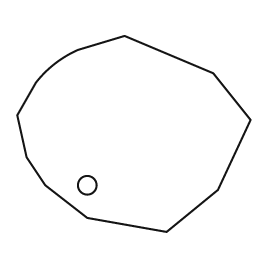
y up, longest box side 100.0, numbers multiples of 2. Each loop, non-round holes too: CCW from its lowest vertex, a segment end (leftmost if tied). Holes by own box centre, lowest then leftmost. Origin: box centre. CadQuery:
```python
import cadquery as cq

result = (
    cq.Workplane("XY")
    .moveTo(14.0, -42.0)
    .lineTo(36.0, -24.0)
    .lineTo(50.0, 6.0)
    .lineTo(34.0, 26.0)
    .lineTo(-4.0, 42.0)
    .lineTo(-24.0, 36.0)
    .threePointArc((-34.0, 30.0), (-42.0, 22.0))
    .lineTo(-50.0, 8.0)
    .lineTo(-46.0, -10.0)
    .lineTo(-38.0, -22.0)
    .lineTo(-20.0, -36.0)
    .close()
    .moveTo(-20.0, -22.0)
    .circle(4.0)
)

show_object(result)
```